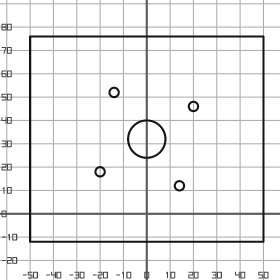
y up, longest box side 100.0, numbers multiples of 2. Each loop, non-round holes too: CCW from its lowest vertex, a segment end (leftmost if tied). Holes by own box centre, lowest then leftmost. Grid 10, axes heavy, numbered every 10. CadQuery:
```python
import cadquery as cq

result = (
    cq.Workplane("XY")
    .moveTo(-50.0, -12.0)
    .lineTo(50.0, -12.0)
    .lineTo(50.0, 76.0)
    .lineTo(-50.0, 76.0)
    .close()
    .moveTo(14.0, 12.0)
    .circle(2.0)
    .moveTo(-20.0, 18.0)
    .circle(2.0)
    .moveTo(0.0, 32.0)
    .circle(8.0)
    .moveTo(20.0, 46.0)
    .circle(2.0)
    .moveTo(-14.0, 52.0)
    .circle(2.0)
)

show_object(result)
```